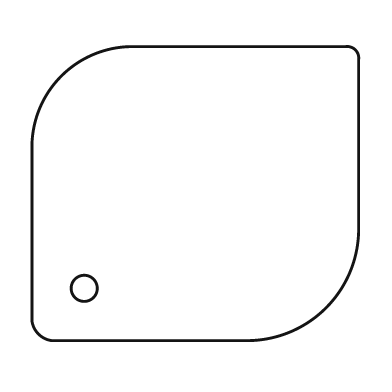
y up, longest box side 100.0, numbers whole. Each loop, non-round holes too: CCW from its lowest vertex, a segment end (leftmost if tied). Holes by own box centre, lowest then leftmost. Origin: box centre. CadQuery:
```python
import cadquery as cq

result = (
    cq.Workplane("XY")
    .moveTo(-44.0, -45.0)
    .lineTo(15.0, -45.0)
    .threePointArc((40.0, -35.0), (50.0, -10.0))
    .lineTo(50.0, 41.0)
    .threePointArc((49.0, 44.0), (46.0, 45.0))
    .lineTo(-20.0, 45.0)
    .threePointArc((-41.0, 36.0), (-50.0, 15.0))
    .lineTo(-50.0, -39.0)
    .threePointArc((-48.0, -43.0), (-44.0, -45.0))
    .close()
    .moveTo(-34.0, -29.0)
    .circle(4.0)
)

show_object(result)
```